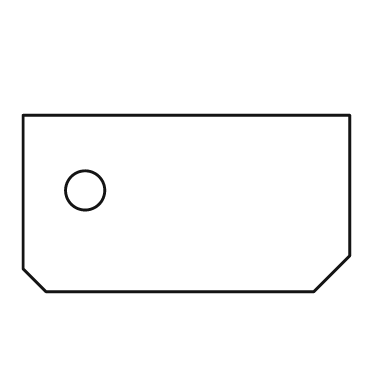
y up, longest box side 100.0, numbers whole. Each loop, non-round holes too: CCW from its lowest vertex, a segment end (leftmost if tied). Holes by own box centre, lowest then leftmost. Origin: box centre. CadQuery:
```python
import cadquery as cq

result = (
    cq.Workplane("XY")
    .moveTo(-43.0, -27.0)
    .lineTo(39.0, -27.0)
    .lineTo(50.0, -16.0)
    .lineTo(50.0, 27.0)
    .lineTo(-50.0, 27.0)
    .lineTo(-50.0, -20.0)
    .close()
    .moveTo(-31.0, 4.0)
    .circle(6.0)
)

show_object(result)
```